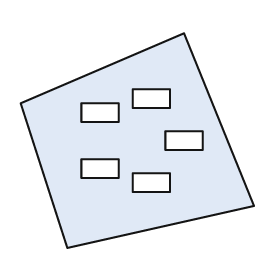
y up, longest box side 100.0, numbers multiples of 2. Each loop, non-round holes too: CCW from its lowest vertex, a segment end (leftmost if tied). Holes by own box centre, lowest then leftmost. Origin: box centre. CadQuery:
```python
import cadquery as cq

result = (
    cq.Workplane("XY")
    .moveTo(-30.0, -46.0)
    .lineTo(50.0, -28.0)
    .lineTo(20.0, 46.0)
    .lineTo(-50.0, 16.0)
    .close()
    .moveTo(-2.0, -22.0)
    .lineTo(14.0, -22.0)
    .lineTo(14.0, -14.0)
    .lineTo(-2.0, -14.0)
    .close()
    .moveTo(-24.0, -16.0)
    .lineTo(-8.0, -16.0)
    .lineTo(-8.0, -8.0)
    .lineTo(-24.0, -8.0)
    .close()
    .moveTo(12.0, -4.0)
    .lineTo(28.0, -4.0)
    .lineTo(28.0, 4.0)
    .lineTo(12.0, 4.0)
    .close()
    .moveTo(-24.0, 8.0)
    .lineTo(-8.0, 8.0)
    .lineTo(-8.0, 16.0)
    .lineTo(-24.0, 16.0)
    .close()
    .moveTo(-2.0, 14.0)
    .lineTo(14.0, 14.0)
    .lineTo(14.0, 22.0)
    .lineTo(-2.0, 22.0)
    .close()
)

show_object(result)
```